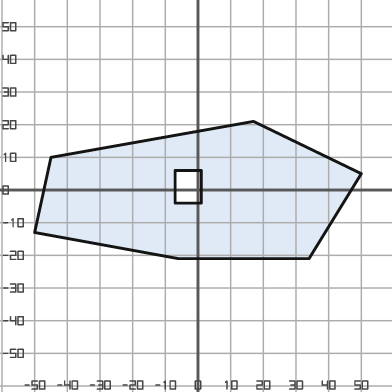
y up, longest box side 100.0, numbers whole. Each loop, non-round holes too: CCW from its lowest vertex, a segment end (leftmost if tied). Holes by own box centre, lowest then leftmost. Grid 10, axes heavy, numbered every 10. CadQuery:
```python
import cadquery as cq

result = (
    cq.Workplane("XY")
    .moveTo(-6.0, -21.0)
    .lineTo(34.0, -21.0)
    .lineTo(50.0, 5.0)
    .lineTo(17.0, 21.0)
    .lineTo(-45.0, 10.0)
    .lineTo(-50.0, -13.0)
    .close()
    .moveTo(-7.0, -4.0)
    .lineTo(1.0, -4.0)
    .lineTo(1.0, 6.0)
    .lineTo(-7.0, 6.0)
    .close()
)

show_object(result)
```